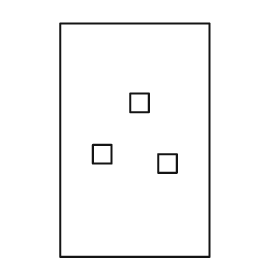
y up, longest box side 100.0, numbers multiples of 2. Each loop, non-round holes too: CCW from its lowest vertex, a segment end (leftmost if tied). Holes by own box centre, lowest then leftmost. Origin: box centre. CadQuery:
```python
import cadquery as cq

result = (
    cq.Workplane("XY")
    .moveTo(-32.0, -50.0)
    .lineTo(32.0, -50.0)
    .lineTo(32.0, 50.0)
    .lineTo(-32.0, 50.0)
    .close()
    .moveTo(10.0, -14.0)
    .lineTo(18.0, -14.0)
    .lineTo(18.0, -6.0)
    .lineTo(10.0, -6.0)
    .close()
    .moveTo(-18.0, -10.0)
    .lineTo(-10.0, -10.0)
    .lineTo(-10.0, -2.0)
    .lineTo(-18.0, -2.0)
    .close()
    .moveTo(-2.0, 12.0)
    .lineTo(6.0, 12.0)
    .lineTo(6.0, 20.0)
    .lineTo(-2.0, 20.0)
    .close()
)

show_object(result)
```